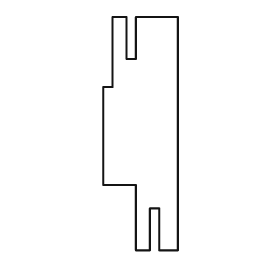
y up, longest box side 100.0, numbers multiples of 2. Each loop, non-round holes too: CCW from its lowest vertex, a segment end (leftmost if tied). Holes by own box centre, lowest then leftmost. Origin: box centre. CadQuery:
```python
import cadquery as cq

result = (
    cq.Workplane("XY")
    .moveTo(-2.0, -50.0)
    .lineTo(4.0, -50.0)
    .lineTo(4.0, -32.0)
    .lineTo(8.0, -32.0)
    .lineTo(8.0, -50.0)
    .lineTo(16.0, -50.0)
    .lineTo(16.0, 50.0)
    .lineTo(-2.0, 50.0)
    .lineTo(-2.0, 32.0)
    .lineTo(-6.0, 32.0)
    .lineTo(-6.0, 50.0)
    .lineTo(-12.0, 50.0)
    .lineTo(-12.0, 20.0)
    .lineTo(-16.0, 20.0)
    .lineTo(-16.0, -22.0)
    .lineTo(-2.0, -22.0)
    .close()
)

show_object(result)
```